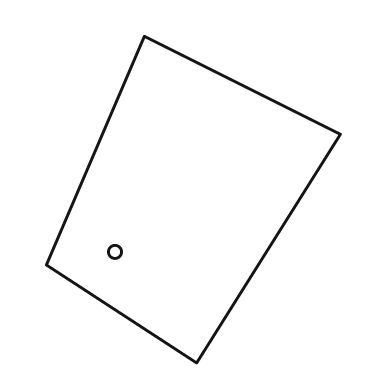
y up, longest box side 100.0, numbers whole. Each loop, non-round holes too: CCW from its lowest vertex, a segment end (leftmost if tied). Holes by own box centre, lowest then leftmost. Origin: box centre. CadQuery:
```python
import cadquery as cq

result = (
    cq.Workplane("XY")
    .moveTo(1.0, -50.0)
    .lineTo(45.0, 20.0)
    .lineTo(-15.0, 50.0)
    .lineTo(-45.0, -20.0)
    .close()
    .moveTo(-24.0, -16.0)
    .circle(2.0)
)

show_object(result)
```